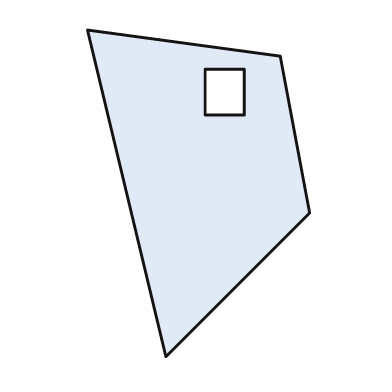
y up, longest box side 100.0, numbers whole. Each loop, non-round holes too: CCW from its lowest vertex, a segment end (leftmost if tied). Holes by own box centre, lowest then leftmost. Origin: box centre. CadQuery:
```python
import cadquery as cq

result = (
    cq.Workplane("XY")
    .moveTo(-10.0, -50.0)
    .lineTo(34.0, -6.0)
    .lineTo(25.0, 42.0)
    .lineTo(-34.0, 50.0)
    .close()
    .moveTo(2.0, 24.0)
    .lineTo(14.0, 24.0)
    .lineTo(14.0, 38.0)
    .lineTo(2.0, 38.0)
    .close()
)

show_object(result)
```